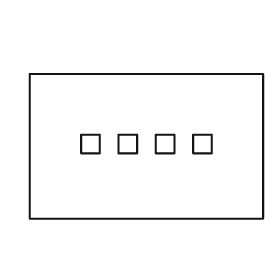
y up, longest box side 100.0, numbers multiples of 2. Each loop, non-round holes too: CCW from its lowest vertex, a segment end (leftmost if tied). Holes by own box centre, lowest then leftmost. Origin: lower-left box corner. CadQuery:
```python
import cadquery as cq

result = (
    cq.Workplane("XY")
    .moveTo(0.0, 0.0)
    .lineTo(100.0, 0.0)
    .lineTo(100.0, 62.0)
    .lineTo(0.0, 62.0)
    .close()
    .moveTo(22.0, 28.0)
    .lineTo(30.0, 28.0)
    .lineTo(30.0, 36.0)
    .lineTo(22.0, 36.0)
    .close()
    .moveTo(38.0, 28.0)
    .lineTo(46.0, 28.0)
    .lineTo(46.0, 36.0)
    .lineTo(38.0, 36.0)
    .close()
    .moveTo(54.0, 28.0)
    .lineTo(62.0, 28.0)
    .lineTo(62.0, 36.0)
    .lineTo(54.0, 36.0)
    .close()
    .moveTo(70.0, 28.0)
    .lineTo(78.0, 28.0)
    .lineTo(78.0, 36.0)
    .lineTo(70.0, 36.0)
    .close()
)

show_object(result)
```